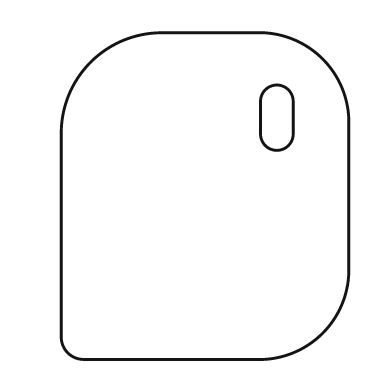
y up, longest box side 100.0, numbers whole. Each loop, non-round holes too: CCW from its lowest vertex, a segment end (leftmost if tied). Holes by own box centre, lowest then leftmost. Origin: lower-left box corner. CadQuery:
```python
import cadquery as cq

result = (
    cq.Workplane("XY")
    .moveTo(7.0, 0.0)
    .lineTo(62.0, 0.0)
    .threePointArc((80.0, 8.0), (88.0, 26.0))
    .lineTo(88.0, 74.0)
    .threePointArc((80.0, 92.0), (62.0, 100.0))
    .lineTo(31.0, 100.0)
    .threePointArc((9.0, 91.0), (0.0, 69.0))
    .lineTo(0.0, 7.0)
    .threePointArc((2.0, 2.0), (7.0, 0.0))
    .close()
    .moveTo(61.0, 69.0)
    .threePointArc((66.0, 64.0), (71.0, 69.0))
    .lineTo(71.0, 79.0)
    .threePointArc((66.0, 84.0), (61.0, 79.0))
    .close()
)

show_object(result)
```